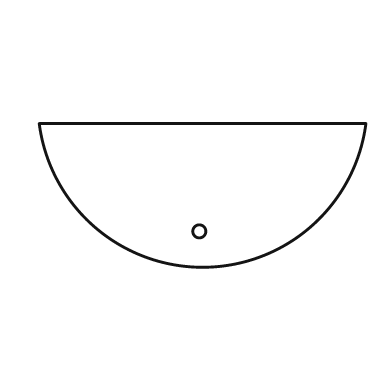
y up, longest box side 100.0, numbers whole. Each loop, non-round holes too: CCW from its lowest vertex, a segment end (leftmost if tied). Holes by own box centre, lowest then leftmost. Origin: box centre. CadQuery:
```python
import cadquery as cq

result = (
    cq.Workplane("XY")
    .moveTo(-50.0, 22.0)
    .threePointArc((0.0, -22.0), (50.0, 22.0))
    .close()
    .moveTo(-1.0, -11.0)
    .circle(2.0)
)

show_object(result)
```